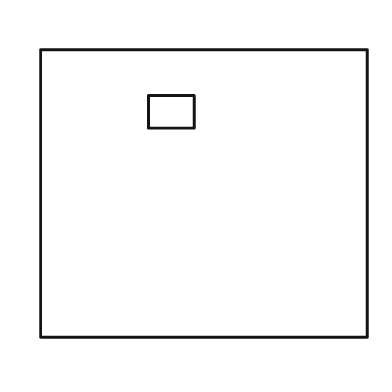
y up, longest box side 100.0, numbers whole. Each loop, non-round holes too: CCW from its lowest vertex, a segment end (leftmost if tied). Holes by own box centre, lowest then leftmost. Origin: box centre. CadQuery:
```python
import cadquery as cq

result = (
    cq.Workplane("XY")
    .moveTo(-50.0, -44.0)
    .lineTo(50.0, -44.0)
    .lineTo(50.0, 44.0)
    .lineTo(-50.0, 44.0)
    .close()
    .moveTo(-17.0, 20.0)
    .lineTo(-3.0, 20.0)
    .lineTo(-3.0, 30.0)
    .lineTo(-17.0, 30.0)
    .close()
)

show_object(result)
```